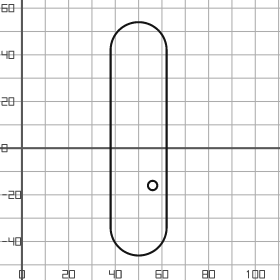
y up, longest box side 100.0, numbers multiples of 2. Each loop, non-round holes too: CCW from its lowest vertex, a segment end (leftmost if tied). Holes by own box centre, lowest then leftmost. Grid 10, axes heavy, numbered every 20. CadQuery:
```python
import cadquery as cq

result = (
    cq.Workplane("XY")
    .moveTo(38.0, -34.0)
    .threePointArc((50.0, -46.0), (62.0, -34.0))
    .lineTo(62.0, 42.0)
    .threePointArc((50.0, 54.0), (38.0, 42.0))
    .close()
    .moveTo(56.0, -16.0)
    .circle(2.0)
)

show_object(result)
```